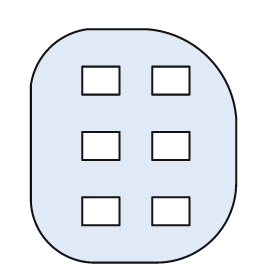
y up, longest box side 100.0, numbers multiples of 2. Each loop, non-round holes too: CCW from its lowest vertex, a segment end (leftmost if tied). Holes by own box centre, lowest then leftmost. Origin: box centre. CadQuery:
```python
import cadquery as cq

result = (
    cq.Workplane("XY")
    .moveTo(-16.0, -50.0)
    .lineTo(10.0, -50.0)
    .threePointArc((34.0, -40.0), (44.0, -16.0))
    .lineTo(44.0, 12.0)
    .threePointArc((32.0, 38.0), (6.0, 50.0))
    .lineTo(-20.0, 50.0)
    .threePointArc((-36.0, 42.0), (-44.0, 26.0))
    .lineTo(-44.0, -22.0)
    .threePointArc((-36.0, -42.0), (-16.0, -50.0))
    .close()
    .moveTo(-22.0, -34.0)
    .lineTo(-6.0, -34.0)
    .lineTo(-6.0, -22.0)
    .lineTo(-22.0, -22.0)
    .close()
    .moveTo(8.0, -34.0)
    .lineTo(24.0, -34.0)
    .lineTo(24.0, -22.0)
    .lineTo(8.0, -22.0)
    .close()
    .moveTo(-22.0, -6.0)
    .lineTo(-6.0, -6.0)
    .lineTo(-6.0, 6.0)
    .lineTo(-22.0, 6.0)
    .close()
    .moveTo(8.0, -6.0)
    .lineTo(24.0, -6.0)
    .lineTo(24.0, 6.0)
    .lineTo(8.0, 6.0)
    .close()
    .moveTo(-22.0, 22.0)
    .lineTo(-6.0, 22.0)
    .lineTo(-6.0, 34.0)
    .lineTo(-22.0, 34.0)
    .close()
    .moveTo(8.0, 22.0)
    .lineTo(24.0, 22.0)
    .lineTo(24.0, 34.0)
    .lineTo(8.0, 34.0)
    .close()
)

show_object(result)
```